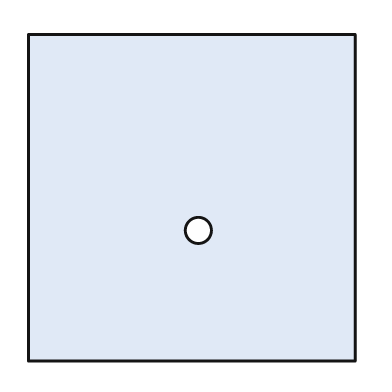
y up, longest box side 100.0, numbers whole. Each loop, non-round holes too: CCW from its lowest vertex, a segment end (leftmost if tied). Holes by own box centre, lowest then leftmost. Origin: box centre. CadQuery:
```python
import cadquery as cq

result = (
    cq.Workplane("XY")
    .moveTo(-50.0, -50.0)
    .lineTo(50.0, -50.0)
    .lineTo(50.0, 50.0)
    .lineTo(-50.0, 50.0)
    .close()
    .moveTo(2.0, -10.0)
    .circle(4.0)
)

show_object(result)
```